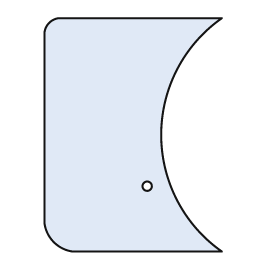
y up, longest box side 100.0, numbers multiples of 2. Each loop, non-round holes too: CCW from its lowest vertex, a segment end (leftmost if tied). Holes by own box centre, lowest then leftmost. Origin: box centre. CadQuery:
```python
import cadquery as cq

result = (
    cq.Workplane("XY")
    .moveTo(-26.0, -50.0)
    .lineTo(38.0, -50.0)
    .threePointArc((12.0, 0.0), (38.0, 50.0))
    .lineTo(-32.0, 50.0)
    .threePointArc((-36.0, 48.0), (-38.0, 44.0))
    .lineTo(-38.0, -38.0)
    .threePointArc((-34.0, -46.0), (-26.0, -50.0))
    .close()
    .moveTo(6.0, -22.0)
    .circle(2.0)
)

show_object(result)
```